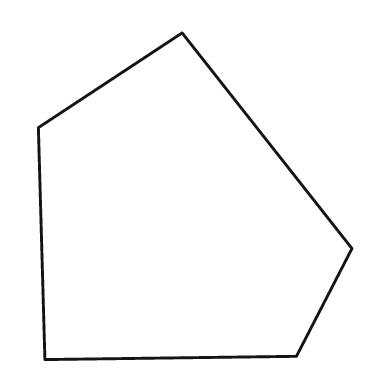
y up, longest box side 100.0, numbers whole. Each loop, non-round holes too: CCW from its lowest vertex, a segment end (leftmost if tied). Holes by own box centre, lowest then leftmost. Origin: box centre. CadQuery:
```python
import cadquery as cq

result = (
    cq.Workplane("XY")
    .moveTo(-46.0, -50.0)
    .lineTo(31.0, -49.0)
    .lineTo(48.0, -16.0)
    .lineTo(-4.0, 50.0)
    .lineTo(-48.0, 21.0)
    .close()
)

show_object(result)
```